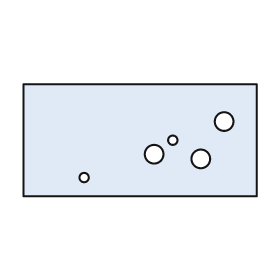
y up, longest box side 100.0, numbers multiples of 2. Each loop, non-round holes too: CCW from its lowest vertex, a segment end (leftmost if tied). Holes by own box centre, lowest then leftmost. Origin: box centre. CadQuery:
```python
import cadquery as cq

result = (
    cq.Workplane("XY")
    .moveTo(-50.0, -24.0)
    .lineTo(50.0, -24.0)
    .lineTo(50.0, 24.0)
    .lineTo(-50.0, 24.0)
    .close()
    .moveTo(-24.0, -16.0)
    .circle(2.0)
    .moveTo(26.0, -8.0)
    .circle(4.0)
    .moveTo(6.0, -6.0)
    .circle(4.0)
    .moveTo(14.0, 0.0)
    .circle(2.0)
    .moveTo(36.0, 8.0)
    .circle(4.0)
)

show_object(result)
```